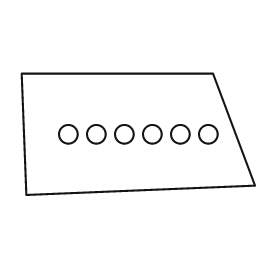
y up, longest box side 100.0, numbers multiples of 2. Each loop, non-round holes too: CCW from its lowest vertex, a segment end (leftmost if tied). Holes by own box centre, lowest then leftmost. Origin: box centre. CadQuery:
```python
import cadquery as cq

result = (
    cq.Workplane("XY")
    .moveTo(-48.0, -26.0)
    .lineTo(50.0, -22.0)
    .lineTo(32.0, 26.0)
    .lineTo(-50.0, 26.0)
    .close()
    .moveTo(-30.0, 0.0)
    .circle(4.0)
    .moveTo(-18.0, 0.0)
    .circle(4.0)
    .moveTo(-6.0, 0.0)
    .circle(4.0)
    .moveTo(6.0, 0.0)
    .circle(4.0)
    .moveTo(18.0, 0.0)
    .circle(4.0)
    .moveTo(30.0, 0.0)
    .circle(4.0)
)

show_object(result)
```